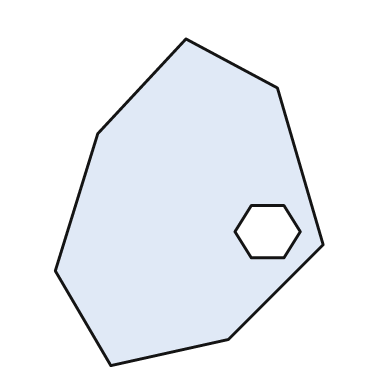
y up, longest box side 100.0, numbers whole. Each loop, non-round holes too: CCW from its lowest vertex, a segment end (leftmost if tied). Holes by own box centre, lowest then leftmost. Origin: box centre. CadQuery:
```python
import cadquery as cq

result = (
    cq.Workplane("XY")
    .moveTo(-24.0, -50.0)
    .lineTo(12.0, -42.0)
    .lineTo(41.0, -13.0)
    .lineTo(27.0, 35.0)
    .lineTo(-1.0, 50.0)
    .lineTo(-28.0, 21.0)
    .lineTo(-41.0, -21.0)
    .close()
    .moveTo(19.0, -17.0)
    .lineTo(29.0, -17.0)
    .lineTo(34.0, -9.0)
    .lineTo(29.0, -1.0)
    .lineTo(19.0, -1.0)
    .lineTo(14.0, -9.0)
    .close()
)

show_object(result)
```